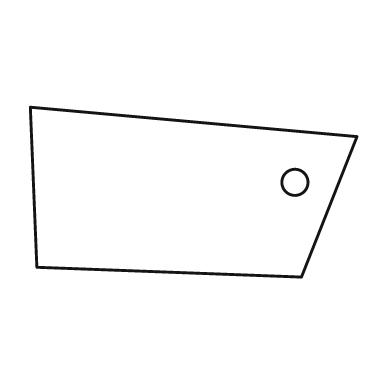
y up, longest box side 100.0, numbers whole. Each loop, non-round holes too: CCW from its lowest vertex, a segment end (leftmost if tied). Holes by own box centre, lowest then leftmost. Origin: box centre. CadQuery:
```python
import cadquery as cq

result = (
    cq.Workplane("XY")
    .moveTo(33.0, -26.0)
    .lineTo(50.0, 17.0)
    .lineTo(-50.0, 26.0)
    .lineTo(-48.0, -23.0)
    .close()
    .moveTo(31.0, 3.0)
    .circle(4.0)
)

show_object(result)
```